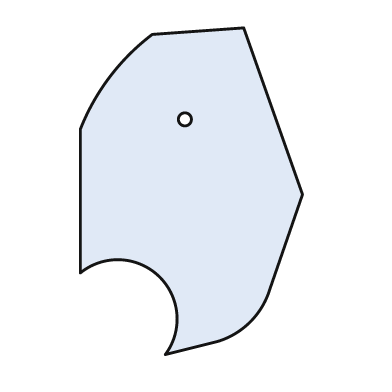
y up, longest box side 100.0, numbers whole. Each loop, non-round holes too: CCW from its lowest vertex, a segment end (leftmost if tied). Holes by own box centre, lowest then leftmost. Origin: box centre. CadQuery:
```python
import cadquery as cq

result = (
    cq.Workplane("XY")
    .moveTo(-8.0, -50.0)
    .lineTo(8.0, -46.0)
    .threePointArc((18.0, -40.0), (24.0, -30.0))
    .lineTo(34.0, -1.0)
    .lineTo(16.0, 50.0)
    .lineTo(-12.0, 48.0)
    .threePointArc((-25.0, 35.0), (-34.0, 19.0))
    .lineTo(-34.0, -25.0)
    .threePointArc((-10.0, -26.0), (-8.0, -50.0))
    .close()
    .moveTo(-2.0, 22.0)
    .circle(2.0)
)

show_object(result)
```